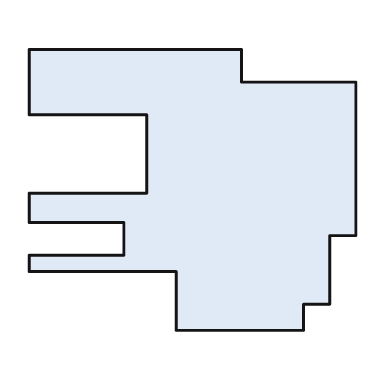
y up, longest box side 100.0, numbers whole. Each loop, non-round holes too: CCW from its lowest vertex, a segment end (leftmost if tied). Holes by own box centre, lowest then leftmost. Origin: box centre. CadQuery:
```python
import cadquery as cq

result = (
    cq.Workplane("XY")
    .moveTo(-5.0, -43.0)
    .lineTo(34.0, -43.0)
    .lineTo(34.0, -35.0)
    .lineTo(42.0, -35.0)
    .lineTo(42.0, -14.0)
    .lineTo(50.0, -14.0)
    .lineTo(50.0, 33.0)
    .lineTo(15.0, 33.0)
    .lineTo(15.0, 43.0)
    .lineTo(-50.0, 43.0)
    .lineTo(-50.0, 23.0)
    .lineTo(-14.0, 23.0)
    .lineTo(-14.0, -1.0)
    .lineTo(-50.0, -1.0)
    .lineTo(-50.0, -10.0)
    .lineTo(-21.0, -10.0)
    .lineTo(-21.0, -20.0)
    .lineTo(-50.0, -20.0)
    .lineTo(-50.0, -25.0)
    .lineTo(-5.0, -25.0)
    .close()
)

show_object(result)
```